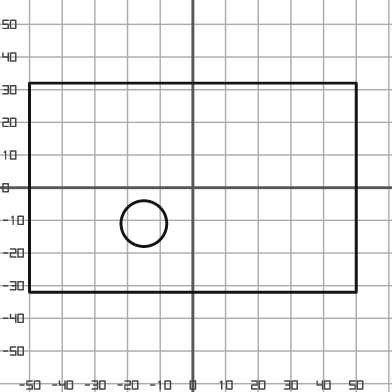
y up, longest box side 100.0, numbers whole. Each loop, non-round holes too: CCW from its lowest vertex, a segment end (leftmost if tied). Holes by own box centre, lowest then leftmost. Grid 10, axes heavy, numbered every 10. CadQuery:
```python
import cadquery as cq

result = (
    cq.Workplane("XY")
    .moveTo(-50.0, -32.0)
    .lineTo(50.0, -32.0)
    .lineTo(50.0, 32.0)
    .lineTo(-50.0, 32.0)
    .close()
    .moveTo(-15.0, -11.0)
    .circle(7.0)
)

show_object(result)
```